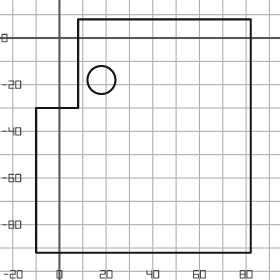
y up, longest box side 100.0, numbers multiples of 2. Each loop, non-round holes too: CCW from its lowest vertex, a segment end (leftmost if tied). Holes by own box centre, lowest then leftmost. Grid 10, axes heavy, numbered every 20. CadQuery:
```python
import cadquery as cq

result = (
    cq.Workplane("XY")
    .moveTo(-10.0, -92.0)
    .lineTo(82.0, -92.0)
    .lineTo(82.0, 8.0)
    .lineTo(8.0, 8.0)
    .lineTo(8.0, -30.0)
    .lineTo(-10.0, -30.0)
    .close()
    .moveTo(18.0, -18.0)
    .circle(6.0)
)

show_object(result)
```